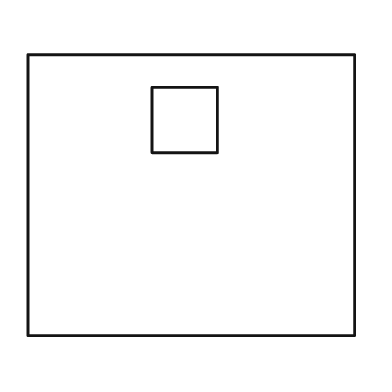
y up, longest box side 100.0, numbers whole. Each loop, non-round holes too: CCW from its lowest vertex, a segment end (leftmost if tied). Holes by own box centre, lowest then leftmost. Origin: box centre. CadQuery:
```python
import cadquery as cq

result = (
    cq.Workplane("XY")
    .moveTo(-50.0, -43.0)
    .lineTo(50.0, -43.0)
    .lineTo(50.0, 43.0)
    .lineTo(-50.0, 43.0)
    .close()
    .moveTo(-12.0, 13.0)
    .lineTo(8.0, 13.0)
    .lineTo(8.0, 33.0)
    .lineTo(-12.0, 33.0)
    .close()
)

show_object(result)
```